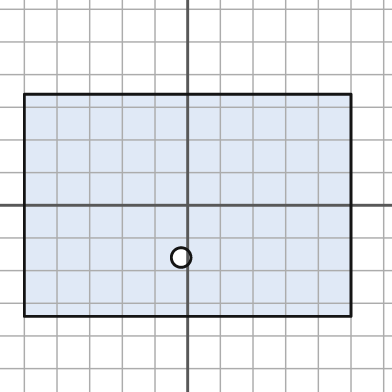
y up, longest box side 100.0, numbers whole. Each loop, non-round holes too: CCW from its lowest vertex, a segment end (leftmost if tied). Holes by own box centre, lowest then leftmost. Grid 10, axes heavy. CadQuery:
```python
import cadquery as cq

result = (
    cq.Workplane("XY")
    .moveTo(-50.0, -34.0)
    .lineTo(50.0, -34.0)
    .lineTo(50.0, 34.0)
    .lineTo(-50.0, 34.0)
    .close()
    .moveTo(-2.0, -16.0)
    .circle(3.0)
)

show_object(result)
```